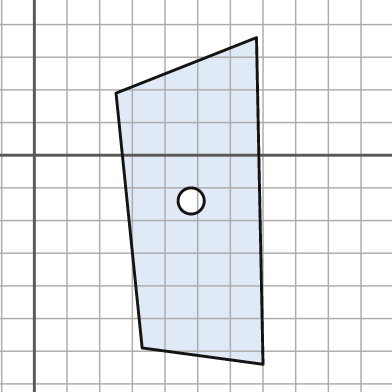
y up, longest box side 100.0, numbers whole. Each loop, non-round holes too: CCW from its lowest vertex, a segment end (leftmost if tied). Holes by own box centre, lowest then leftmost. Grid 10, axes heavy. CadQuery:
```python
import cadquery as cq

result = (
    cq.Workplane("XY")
    .moveTo(70.0, -64.0)
    .lineTo(68.0, 36.0)
    .lineTo(25.0, 19.0)
    .lineTo(33.0, -59.0)
    .close()
    .moveTo(48.0, -14.0)
    .circle(4.0)
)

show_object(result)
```